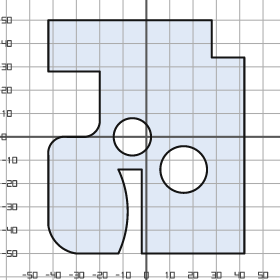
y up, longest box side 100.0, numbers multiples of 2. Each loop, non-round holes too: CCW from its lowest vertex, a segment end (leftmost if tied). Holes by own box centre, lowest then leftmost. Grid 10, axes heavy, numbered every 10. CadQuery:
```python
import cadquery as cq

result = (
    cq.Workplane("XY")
    .moveTo(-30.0, -50.0)
    .lineTo(-12.0, -50.0)
    .threePointArc((-8.0, -32.0), (-12.0, -14.0))
    .lineTo(-2.0, -14.0)
    .lineTo(-2.0, -50.0)
    .lineTo(42.0, -50.0)
    .lineTo(42.0, 34.0)
    .lineTo(28.0, 34.0)
    .lineTo(28.0, 50.0)
    .lineTo(-42.0, 50.0)
    .lineTo(-42.0, 28.0)
    .lineTo(-20.0, 28.0)
    .lineTo(-20.0, 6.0)
    .threePointArc((-22.0, 2.0), (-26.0, 0.0))
    .lineTo(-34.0, 0.0)
    .threePointArc((-40.0, -2.0), (-42.0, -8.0))
    .lineTo(-42.0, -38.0)
    .threePointArc((-38.0, -46.0), (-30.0, -50.0))
    .close()
    .moveTo(16.0, -14.0)
    .circle(10.0)
    .moveTo(-6.0, 0.0)
    .circle(8.0)
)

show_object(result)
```